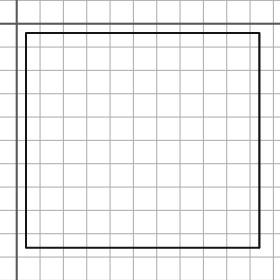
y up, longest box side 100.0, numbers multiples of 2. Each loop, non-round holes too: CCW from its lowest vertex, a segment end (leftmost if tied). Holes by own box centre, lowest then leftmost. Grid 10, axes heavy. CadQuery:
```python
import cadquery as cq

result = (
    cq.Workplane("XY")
    .moveTo(4.0, -96.0)
    .lineTo(104.0, -96.0)
    .lineTo(104.0, -4.0)
    .lineTo(4.0, -4.0)
    .close()
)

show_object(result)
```